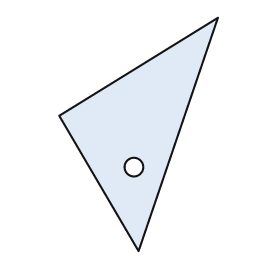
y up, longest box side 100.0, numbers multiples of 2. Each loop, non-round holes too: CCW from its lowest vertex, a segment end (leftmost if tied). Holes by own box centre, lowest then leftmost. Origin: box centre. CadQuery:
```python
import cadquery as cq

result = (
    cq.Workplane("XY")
    .moveTo(0.0, -50.0)
    .lineTo(34.0, 50.0)
    .lineTo(-34.0, 8.0)
    .close()
    .moveTo(-2.0, -14.0)
    .circle(4.0)
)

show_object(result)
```